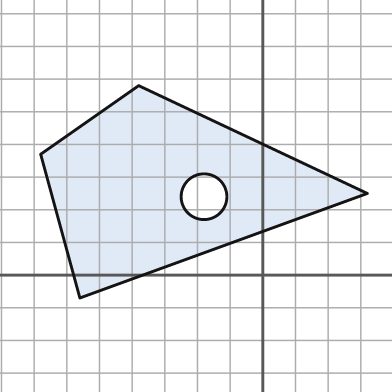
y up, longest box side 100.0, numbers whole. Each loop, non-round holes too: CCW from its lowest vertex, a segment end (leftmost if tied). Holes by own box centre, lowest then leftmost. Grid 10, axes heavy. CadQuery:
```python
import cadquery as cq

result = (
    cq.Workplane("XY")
    .moveTo(-56.0, -7.0)
    .lineTo(32.0, 25.0)
    .lineTo(-38.0, 58.0)
    .lineTo(-68.0, 37.0)
    .close()
    .moveTo(-18.0, 24.0)
    .circle(7.0)
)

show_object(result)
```